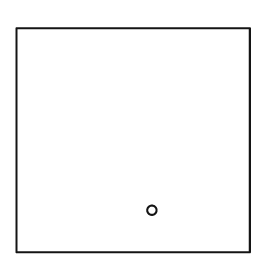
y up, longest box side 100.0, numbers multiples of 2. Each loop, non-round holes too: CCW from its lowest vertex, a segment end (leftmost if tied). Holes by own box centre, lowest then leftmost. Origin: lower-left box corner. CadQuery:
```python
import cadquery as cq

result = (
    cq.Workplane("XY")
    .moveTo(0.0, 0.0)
    .lineTo(100.0, 0.0)
    .lineTo(100.0, 96.0)
    .lineTo(0.0, 96.0)
    .close()
    .moveTo(58.0, 18.0)
    .circle(2.0)
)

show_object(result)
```